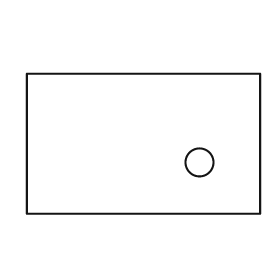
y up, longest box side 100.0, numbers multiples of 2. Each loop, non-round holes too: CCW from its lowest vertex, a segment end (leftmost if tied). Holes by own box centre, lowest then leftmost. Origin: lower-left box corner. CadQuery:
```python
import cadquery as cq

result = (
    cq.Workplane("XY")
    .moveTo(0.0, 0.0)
    .lineTo(100.0, 0.0)
    .lineTo(100.0, 60.0)
    .lineTo(0.0, 60.0)
    .close()
    .moveTo(74.0, 22.0)
    .circle(6.0)
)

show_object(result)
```